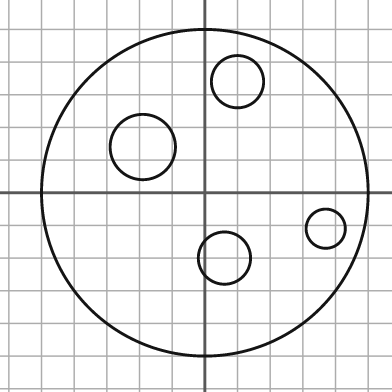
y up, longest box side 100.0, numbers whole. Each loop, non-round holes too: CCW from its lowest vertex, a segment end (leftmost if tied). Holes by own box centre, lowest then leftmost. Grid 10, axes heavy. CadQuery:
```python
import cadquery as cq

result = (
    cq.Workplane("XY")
    .moveTo(0.0, 0.0)
    .circle(50.0)
    .moveTo(6.0, -20.0)
    .circle(8.0)
    .moveTo(37.0, -11.0)
    .circle(6.0)
    .moveTo(-19.0, 14.0)
    .circle(10.0)
    .moveTo(10.0, 34.0)
    .circle(8.0)
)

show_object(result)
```